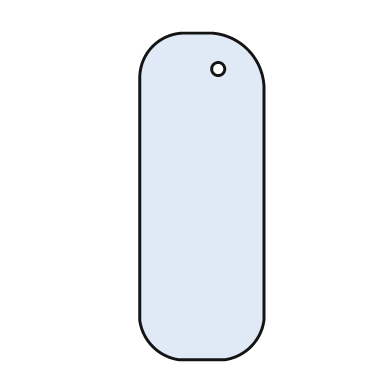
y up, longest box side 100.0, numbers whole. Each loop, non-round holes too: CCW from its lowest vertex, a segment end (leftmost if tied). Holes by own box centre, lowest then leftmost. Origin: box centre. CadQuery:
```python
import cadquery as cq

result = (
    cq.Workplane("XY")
    .moveTo(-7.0, -50.0)
    .lineTo(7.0, -50.0)
    .threePointArc((15.0, -46.0), (19.0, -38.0))
    .lineTo(19.0, 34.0)
    .threePointArc((14.0, 45.0), (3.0, 50.0))
    .lineTo(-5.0, 50.0)
    .threePointArc((-15.0, 46.0), (-19.0, 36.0))
    .lineTo(-19.0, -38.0)
    .threePointArc((-15.0, -46.0), (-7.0, -50.0))
    .close()
    .moveTo(5.0, 39.0)
    .circle(2.0)
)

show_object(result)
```